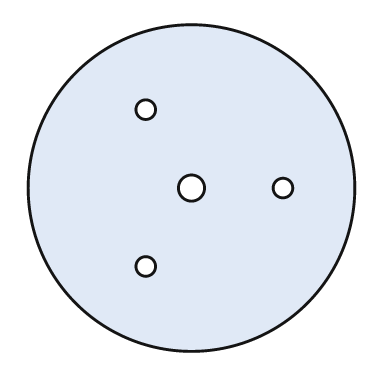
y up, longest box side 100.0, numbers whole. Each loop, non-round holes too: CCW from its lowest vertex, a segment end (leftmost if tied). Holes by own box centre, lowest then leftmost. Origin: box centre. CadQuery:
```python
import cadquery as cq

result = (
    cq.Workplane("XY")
    .moveTo(0.0, 0.0)
    .circle(50.0)
    .moveTo(-14.0, -24.0)
    .circle(3.0)
    .moveTo(0.0, 0.0)
    .circle(4.0)
    .moveTo(28.0, 0.0)
    .circle(3.0)
    .moveTo(-14.0, 24.0)
    .circle(3.0)
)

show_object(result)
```